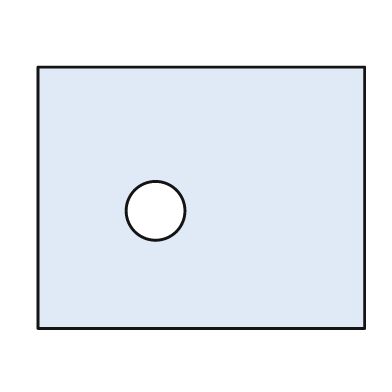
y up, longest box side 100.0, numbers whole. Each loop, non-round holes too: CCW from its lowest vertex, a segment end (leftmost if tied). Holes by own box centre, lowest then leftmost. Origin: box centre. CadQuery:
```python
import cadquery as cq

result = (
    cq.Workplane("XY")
    .moveTo(-50.0, -40.0)
    .lineTo(50.0, -40.0)
    .lineTo(50.0, 40.0)
    .lineTo(-50.0, 40.0)
    .close()
    .moveTo(-14.0, -4.0)
    .circle(9.0)
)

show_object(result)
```